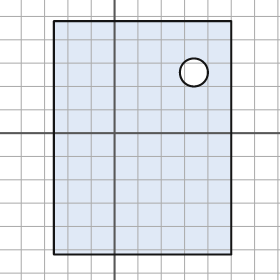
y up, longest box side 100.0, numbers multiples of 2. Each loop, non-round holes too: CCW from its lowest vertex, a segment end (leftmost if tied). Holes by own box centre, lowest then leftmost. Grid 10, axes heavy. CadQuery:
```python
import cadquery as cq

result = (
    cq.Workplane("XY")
    .moveTo(-26.0, -52.0)
    .lineTo(50.0, -52.0)
    .lineTo(50.0, 48.0)
    .lineTo(-26.0, 48.0)
    .close()
    .moveTo(34.0, 26.0)
    .circle(6.0)
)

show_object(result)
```